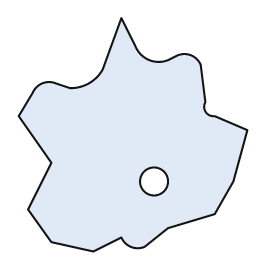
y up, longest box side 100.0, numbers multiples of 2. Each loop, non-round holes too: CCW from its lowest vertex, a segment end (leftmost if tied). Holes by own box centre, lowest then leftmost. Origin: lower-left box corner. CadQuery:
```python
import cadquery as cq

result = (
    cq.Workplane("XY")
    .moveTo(32.0, 0.0)
    .lineTo(44.0, 6.0)
    .threePointArc((48.0, 2.0), (54.0, 2.0))
    .lineTo(64.0, 10.0)
    .lineTo(84.0, 16.0)
    .lineTo(92.0, 30.0)
    .lineTo(98.0, 52.0)
    .lineTo(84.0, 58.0)
    .threePointArc((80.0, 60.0), (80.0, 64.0))
    .lineTo(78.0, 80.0)
    .threePointArc((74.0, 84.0), (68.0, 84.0))
    .lineTo(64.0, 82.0)
    .threePointArc((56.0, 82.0), (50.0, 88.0))
    .lineTo(44.0, 100.0)
    .lineTo(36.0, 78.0)
    .threePointArc((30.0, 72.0), (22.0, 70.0))
    .lineTo(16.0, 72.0)
    .threePointArc((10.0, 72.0), (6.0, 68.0))
    .lineTo(0.0, 58.0)
    .lineTo(14.0, 38.0)
    .lineTo(4.0, 18.0)
    .lineTo(14.0, 4.0)
    .close()
    .moveTo(58.0, 30.0)
    .circle(6.0)
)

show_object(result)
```